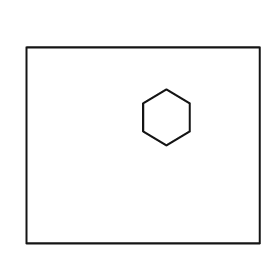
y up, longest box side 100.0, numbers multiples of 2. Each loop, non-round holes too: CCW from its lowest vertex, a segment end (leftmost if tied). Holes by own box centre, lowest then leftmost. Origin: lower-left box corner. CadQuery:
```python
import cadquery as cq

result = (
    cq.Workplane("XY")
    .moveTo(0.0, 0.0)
    .lineTo(100.0, 0.0)
    .lineTo(100.0, 84.0)
    .lineTo(0.0, 84.0)
    .close()
    .moveTo(60.0, 42.0)
    .lineTo(70.0, 48.0)
    .lineTo(70.0, 60.0)
    .lineTo(60.0, 66.0)
    .lineTo(50.0, 60.0)
    .lineTo(50.0, 48.0)
    .close()
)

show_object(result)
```